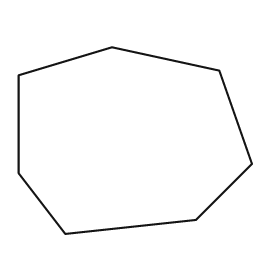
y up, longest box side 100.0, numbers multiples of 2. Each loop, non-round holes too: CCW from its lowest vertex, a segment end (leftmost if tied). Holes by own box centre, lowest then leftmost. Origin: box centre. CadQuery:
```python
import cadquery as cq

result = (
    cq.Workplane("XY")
    .moveTo(-30.0, -40.0)
    .lineTo(26.0, -34.0)
    .lineTo(50.0, -10.0)
    .lineTo(36.0, 30.0)
    .lineTo(-10.0, 40.0)
    .lineTo(-50.0, 28.0)
    .lineTo(-50.0, -14.0)
    .close()
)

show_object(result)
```